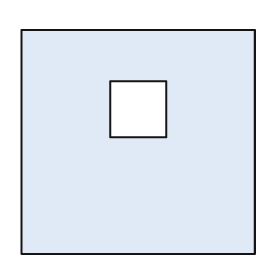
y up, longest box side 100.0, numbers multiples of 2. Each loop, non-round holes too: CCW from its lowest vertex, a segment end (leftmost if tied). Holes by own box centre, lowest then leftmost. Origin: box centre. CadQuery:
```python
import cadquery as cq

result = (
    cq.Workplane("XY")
    .moveTo(-50.0, -48.0)
    .lineTo(50.0, -48.0)
    .lineTo(50.0, 48.0)
    .lineTo(-50.0, 48.0)
    .close()
    .moveTo(-12.0, 2.0)
    .lineTo(12.0, 2.0)
    .lineTo(12.0, 26.0)
    .lineTo(-12.0, 26.0)
    .close()
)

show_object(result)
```